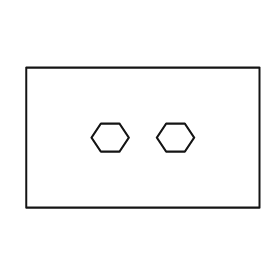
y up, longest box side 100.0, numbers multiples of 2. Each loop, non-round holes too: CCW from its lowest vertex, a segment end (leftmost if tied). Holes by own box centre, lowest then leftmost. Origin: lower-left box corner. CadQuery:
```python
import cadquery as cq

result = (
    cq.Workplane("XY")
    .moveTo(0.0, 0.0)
    .lineTo(100.0, 0.0)
    .lineTo(100.0, 60.0)
    .lineTo(0.0, 60.0)
    .close()
    .moveTo(32.0, 24.0)
    .lineTo(40.0, 24.0)
    .lineTo(44.0, 30.0)
    .lineTo(40.0, 36.0)
    .lineTo(32.0, 36.0)
    .lineTo(28.0, 30.0)
    .close()
    .moveTo(60.0, 24.0)
    .lineTo(68.0, 24.0)
    .lineTo(72.0, 30.0)
    .lineTo(68.0, 36.0)
    .lineTo(60.0, 36.0)
    .lineTo(56.0, 30.0)
    .close()
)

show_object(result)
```